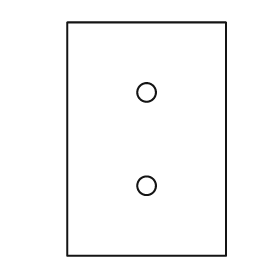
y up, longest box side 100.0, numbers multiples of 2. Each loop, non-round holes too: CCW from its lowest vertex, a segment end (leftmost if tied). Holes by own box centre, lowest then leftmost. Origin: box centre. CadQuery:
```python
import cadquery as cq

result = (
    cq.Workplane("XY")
    .moveTo(-34.0, -50.0)
    .lineTo(34.0, -50.0)
    .lineTo(34.0, 50.0)
    .lineTo(-34.0, 50.0)
    .close()
    .moveTo(0.0, -20.0)
    .circle(4.0)
    .moveTo(0.0, 20.0)
    .circle(4.0)
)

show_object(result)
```